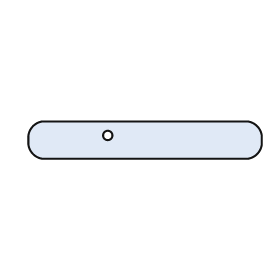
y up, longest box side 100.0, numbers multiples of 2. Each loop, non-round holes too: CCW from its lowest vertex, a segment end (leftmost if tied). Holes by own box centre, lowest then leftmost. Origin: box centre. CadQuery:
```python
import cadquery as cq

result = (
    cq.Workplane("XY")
    .moveTo(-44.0, -8.0)
    .lineTo(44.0, -8.0)
    .threePointArc((48.0, -6.0), (50.0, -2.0))
    .lineTo(50.0, 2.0)
    .threePointArc((48.0, 6.0), (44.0, 8.0))
    .lineTo(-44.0, 8.0)
    .threePointArc((-48.0, 6.0), (-50.0, 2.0))
    .lineTo(-50.0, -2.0)
    .threePointArc((-48.0, -6.0), (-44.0, -8.0))
    .close()
    .moveTo(-16.0, 2.0)
    .circle(2.0)
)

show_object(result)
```